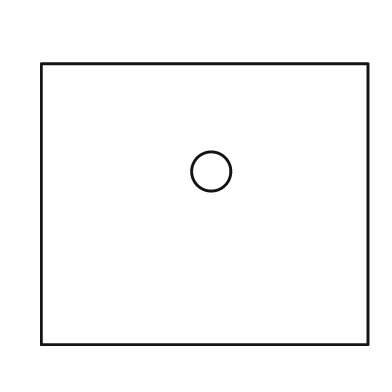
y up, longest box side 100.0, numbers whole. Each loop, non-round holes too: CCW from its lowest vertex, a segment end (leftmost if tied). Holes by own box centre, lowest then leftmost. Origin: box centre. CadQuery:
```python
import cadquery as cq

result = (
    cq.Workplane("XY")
    .moveTo(-50.0, -43.0)
    .lineTo(50.0, -43.0)
    .lineTo(50.0, 43.0)
    .lineTo(-50.0, 43.0)
    .close()
    .moveTo(2.0, 10.0)
    .circle(6.0)
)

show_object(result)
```